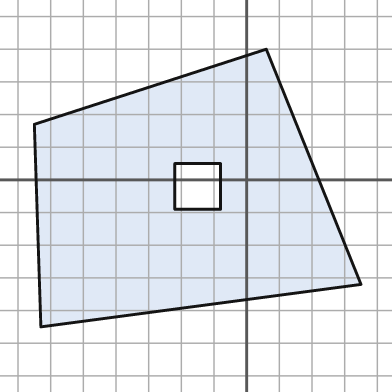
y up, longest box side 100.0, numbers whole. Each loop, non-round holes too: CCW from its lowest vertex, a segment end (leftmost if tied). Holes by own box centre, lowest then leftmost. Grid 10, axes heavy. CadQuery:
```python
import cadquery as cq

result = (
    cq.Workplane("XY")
    .moveTo(-63.0, -45.0)
    .lineTo(35.0, -32.0)
    .lineTo(6.0, 40.0)
    .lineTo(-65.0, 17.0)
    .close()
    .moveTo(-22.0, -9.0)
    .lineTo(-8.0, -9.0)
    .lineTo(-8.0, 5.0)
    .lineTo(-22.0, 5.0)
    .close()
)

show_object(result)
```